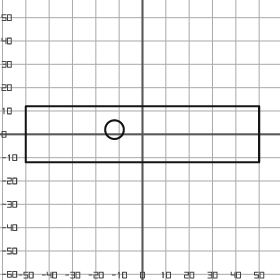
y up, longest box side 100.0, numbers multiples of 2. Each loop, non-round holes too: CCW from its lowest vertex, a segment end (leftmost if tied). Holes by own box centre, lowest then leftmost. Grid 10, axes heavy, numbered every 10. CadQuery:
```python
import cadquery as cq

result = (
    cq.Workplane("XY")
    .moveTo(-50.0, -12.0)
    .lineTo(50.0, -12.0)
    .lineTo(50.0, 12.0)
    .lineTo(-50.0, 12.0)
    .close()
    .moveTo(-12.0, 2.0)
    .circle(4.0)
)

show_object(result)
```